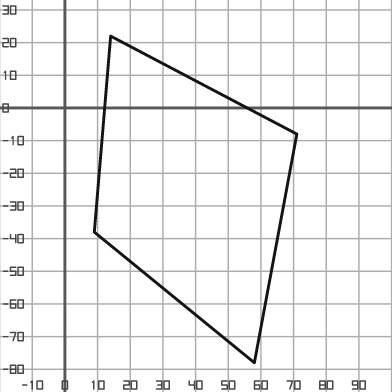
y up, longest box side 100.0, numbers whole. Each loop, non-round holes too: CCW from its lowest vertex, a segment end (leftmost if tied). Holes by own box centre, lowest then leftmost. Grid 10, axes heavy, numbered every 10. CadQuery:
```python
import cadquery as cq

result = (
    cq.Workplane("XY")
    .moveTo(58.0, -78.0)
    .lineTo(71.0, -8.0)
    .lineTo(14.0, 22.0)
    .lineTo(9.0, -38.0)
    .close()
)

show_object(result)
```